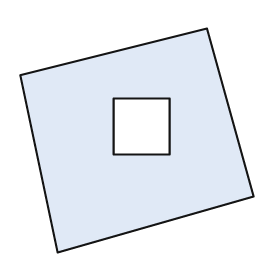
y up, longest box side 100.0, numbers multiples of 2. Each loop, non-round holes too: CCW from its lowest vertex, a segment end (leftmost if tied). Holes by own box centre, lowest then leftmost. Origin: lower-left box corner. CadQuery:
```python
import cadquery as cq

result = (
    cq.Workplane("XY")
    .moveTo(16.0, 0.0)
    .lineTo(100.0, 24.0)
    .lineTo(80.0, 96.0)
    .lineTo(0.0, 76.0)
    .close()
    .moveTo(40.0, 42.0)
    .lineTo(64.0, 42.0)
    .lineTo(64.0, 66.0)
    .lineTo(40.0, 66.0)
    .close()
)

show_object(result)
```